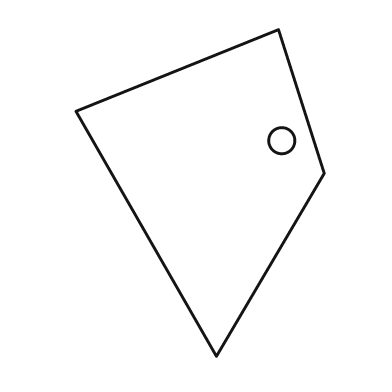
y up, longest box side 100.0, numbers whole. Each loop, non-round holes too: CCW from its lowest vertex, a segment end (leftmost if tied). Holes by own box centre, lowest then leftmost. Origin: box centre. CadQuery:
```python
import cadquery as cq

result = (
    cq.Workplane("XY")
    .moveTo(5.0, -50.0)
    .lineTo(38.0, 6.0)
    .lineTo(24.0, 50.0)
    .lineTo(-38.0, 25.0)
    .close()
    .moveTo(25.0, 16.0)
    .circle(4.0)
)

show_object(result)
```